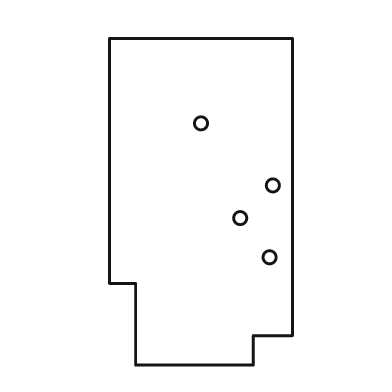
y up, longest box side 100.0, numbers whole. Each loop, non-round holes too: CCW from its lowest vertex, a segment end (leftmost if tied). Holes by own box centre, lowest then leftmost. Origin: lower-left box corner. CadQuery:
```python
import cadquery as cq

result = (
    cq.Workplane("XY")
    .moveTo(8.0, 0.0)
    .lineTo(44.0, 0.0)
    .lineTo(44.0, 9.0)
    .lineTo(56.0, 9.0)
    .lineTo(56.0, 100.0)
    .lineTo(0.0, 100.0)
    .lineTo(0.0, 25.0)
    .lineTo(8.0, 25.0)
    .close()
    .moveTo(49.0, 33.0)
    .circle(2.0)
    .moveTo(40.0, 45.0)
    .circle(2.0)
    .moveTo(50.0, 55.0)
    .circle(2.0)
    .moveTo(28.0, 74.0)
    .circle(2.0)
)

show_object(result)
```